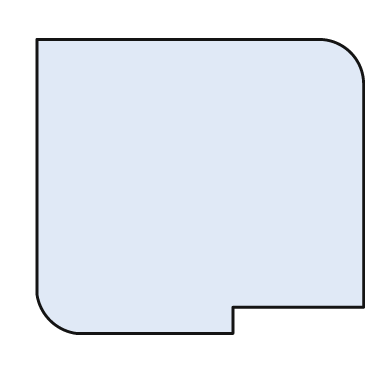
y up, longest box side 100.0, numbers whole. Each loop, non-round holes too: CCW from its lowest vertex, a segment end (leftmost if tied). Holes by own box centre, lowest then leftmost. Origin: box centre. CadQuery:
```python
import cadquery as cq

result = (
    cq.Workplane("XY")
    .moveTo(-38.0, -45.0)
    .lineTo(10.0, -45.0)
    .lineTo(10.0, -37.0)
    .lineTo(50.0, -37.0)
    .lineTo(50.0, 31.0)
    .threePointArc((46.0, 41.0), (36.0, 45.0))
    .lineTo(-50.0, 45.0)
    .lineTo(-50.0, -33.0)
    .threePointArc((-46.0, -41.0), (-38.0, -45.0))
    .close()
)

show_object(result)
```